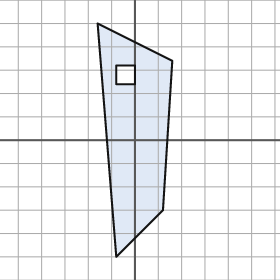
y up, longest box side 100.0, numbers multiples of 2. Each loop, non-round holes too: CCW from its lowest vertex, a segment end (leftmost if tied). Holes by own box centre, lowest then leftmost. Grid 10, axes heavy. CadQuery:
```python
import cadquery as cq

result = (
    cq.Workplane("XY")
    .moveTo(-8.0, -50.0)
    .lineTo(12.0, -30.0)
    .lineTo(16.0, 34.0)
    .lineTo(-16.0, 50.0)
    .close()
    .moveTo(-8.0, 24.0)
    .lineTo(0.0, 24.0)
    .lineTo(0.0, 32.0)
    .lineTo(-8.0, 32.0)
    .close()
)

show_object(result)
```